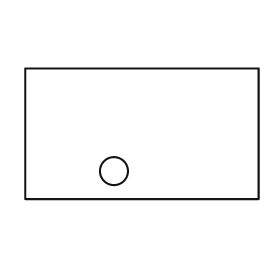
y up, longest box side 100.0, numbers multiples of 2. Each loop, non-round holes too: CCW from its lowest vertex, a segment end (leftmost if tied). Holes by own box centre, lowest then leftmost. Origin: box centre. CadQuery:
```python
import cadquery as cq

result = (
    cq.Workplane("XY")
    .moveTo(-50.0, -28.0)
    .lineTo(50.0, -28.0)
    .lineTo(50.0, 28.0)
    .lineTo(-50.0, 28.0)
    .close()
    .moveTo(-12.0, -16.0)
    .circle(6.0)
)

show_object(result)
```